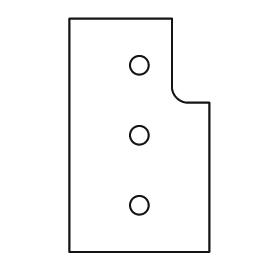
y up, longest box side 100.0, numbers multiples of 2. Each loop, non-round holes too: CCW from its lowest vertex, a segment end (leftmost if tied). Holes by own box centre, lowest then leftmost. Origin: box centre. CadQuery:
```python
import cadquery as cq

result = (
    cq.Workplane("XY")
    .moveTo(-30.0, -50.0)
    .lineTo(30.0, -50.0)
    .lineTo(30.0, 14.0)
    .lineTo(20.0, 14.0)
    .threePointArc((16.0, 16.0), (14.0, 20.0))
    .lineTo(14.0, 50.0)
    .lineTo(-30.0, 50.0)
    .close()
    .moveTo(0.0, -30.0)
    .circle(4.0)
    .moveTo(0.0, 0.0)
    .circle(4.0)
    .moveTo(0.0, 30.0)
    .circle(4.0)
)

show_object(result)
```